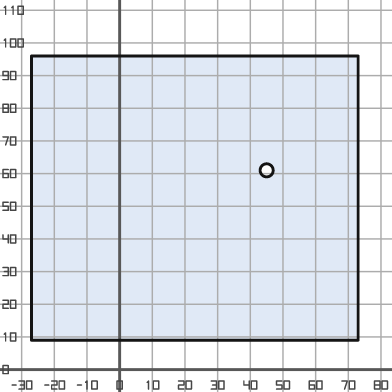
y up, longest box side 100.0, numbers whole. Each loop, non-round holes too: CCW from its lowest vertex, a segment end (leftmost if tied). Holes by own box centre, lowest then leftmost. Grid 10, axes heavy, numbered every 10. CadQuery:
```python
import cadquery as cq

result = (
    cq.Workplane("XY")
    .moveTo(-27.0, 9.0)
    .lineTo(73.0, 9.0)
    .lineTo(73.0, 96.0)
    .lineTo(-27.0, 96.0)
    .close()
    .moveTo(45.0, 61.0)
    .circle(2.0)
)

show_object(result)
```